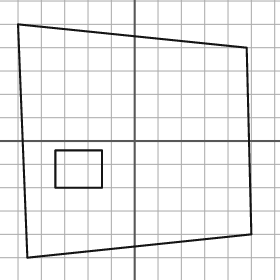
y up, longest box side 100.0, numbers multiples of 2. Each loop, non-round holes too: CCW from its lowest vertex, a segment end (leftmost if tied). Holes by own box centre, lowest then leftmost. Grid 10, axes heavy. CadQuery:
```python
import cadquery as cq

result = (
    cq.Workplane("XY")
    .moveTo(-46.0, -50.0)
    .lineTo(50.0, -40.0)
    .lineTo(48.0, 40.0)
    .lineTo(-50.0, 50.0)
    .close()
    .moveTo(-34.0, -20.0)
    .lineTo(-14.0, -20.0)
    .lineTo(-14.0, -4.0)
    .lineTo(-34.0, -4.0)
    .close()
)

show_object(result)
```